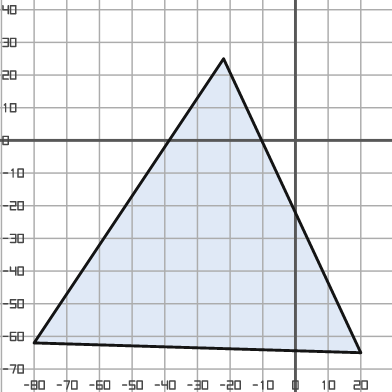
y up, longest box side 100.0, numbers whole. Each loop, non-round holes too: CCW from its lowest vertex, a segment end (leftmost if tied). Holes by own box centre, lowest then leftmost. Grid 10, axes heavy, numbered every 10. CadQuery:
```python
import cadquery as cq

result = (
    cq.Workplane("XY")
    .moveTo(20.0, -65.0)
    .lineTo(-22.0, 25.0)
    .lineTo(-80.0, -62.0)
    .close()
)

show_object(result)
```